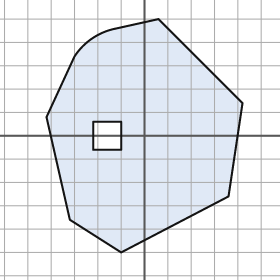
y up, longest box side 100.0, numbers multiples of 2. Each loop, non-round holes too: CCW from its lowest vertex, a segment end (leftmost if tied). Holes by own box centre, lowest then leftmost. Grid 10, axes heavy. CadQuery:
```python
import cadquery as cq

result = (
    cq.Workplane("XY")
    .moveTo(-10.0, -50.0)
    .lineTo(36.0, -26.0)
    .lineTo(42.0, 14.0)
    .lineTo(6.0, 50.0)
    .lineTo(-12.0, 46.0)
    .threePointArc((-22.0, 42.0), (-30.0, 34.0))
    .lineTo(-42.0, 8.0)
    .lineTo(-32.0, -36.0)
    .close()
    .moveTo(-22.0, -6.0)
    .lineTo(-10.0, -6.0)
    .lineTo(-10.0, 6.0)
    .lineTo(-22.0, 6.0)
    .close()
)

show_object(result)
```